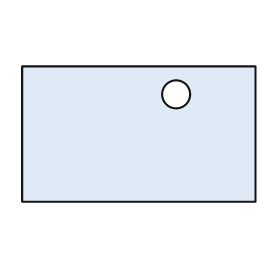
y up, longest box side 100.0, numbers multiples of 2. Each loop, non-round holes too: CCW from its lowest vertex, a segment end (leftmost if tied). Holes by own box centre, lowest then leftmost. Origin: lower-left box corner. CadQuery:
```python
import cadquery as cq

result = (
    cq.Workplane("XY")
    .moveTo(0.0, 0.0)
    .lineTo(100.0, 0.0)
    .lineTo(100.0, 58.0)
    .lineTo(0.0, 58.0)
    .close()
    .moveTo(66.0, 46.0)
    .circle(6.0)
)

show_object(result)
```